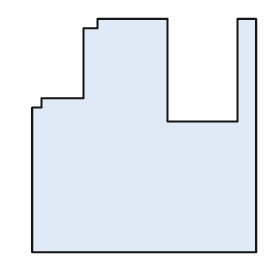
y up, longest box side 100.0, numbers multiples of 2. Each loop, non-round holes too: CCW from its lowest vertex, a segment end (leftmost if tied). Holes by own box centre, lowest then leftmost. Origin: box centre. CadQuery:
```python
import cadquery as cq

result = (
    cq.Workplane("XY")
    .moveTo(-48.0, -50.0)
    .lineTo(48.0, -50.0)
    .lineTo(48.0, 50.0)
    .lineTo(40.0, 50.0)
    .lineTo(40.0, 6.0)
    .lineTo(10.0, 6.0)
    .lineTo(10.0, 50.0)
    .lineTo(-20.0, 50.0)
    .lineTo(-20.0, 46.0)
    .lineTo(-26.0, 46.0)
    .lineTo(-26.0, 16.0)
    .lineTo(-44.0, 16.0)
    .lineTo(-44.0, 12.0)
    .lineTo(-48.0, 12.0)
    .close()
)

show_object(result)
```